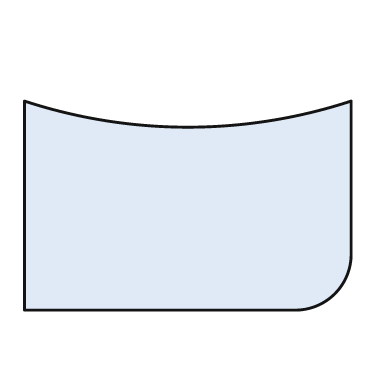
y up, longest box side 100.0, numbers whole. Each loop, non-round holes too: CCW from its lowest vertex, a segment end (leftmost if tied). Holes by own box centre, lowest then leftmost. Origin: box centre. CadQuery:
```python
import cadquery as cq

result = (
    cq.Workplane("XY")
    .moveTo(-50.0, -32.0)
    .lineTo(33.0, -32.0)
    .threePointArc((45.0, -27.0), (50.0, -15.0))
    .lineTo(50.0, 32.0)
    .threePointArc((0.0, 24.0), (-50.0, 32.0))
    .close()
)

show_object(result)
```